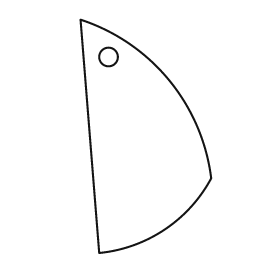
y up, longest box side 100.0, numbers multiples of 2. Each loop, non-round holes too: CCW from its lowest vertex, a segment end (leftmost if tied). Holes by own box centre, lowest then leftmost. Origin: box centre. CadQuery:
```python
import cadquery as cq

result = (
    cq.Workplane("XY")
    .moveTo(-20.0, -50.0)
    .threePointArc((8.0, -40.0), (28.0, -18.0))
    .threePointArc((10.0, 24.0), (-28.0, 50.0))
    .close()
    .moveTo(-16.0, 34.0)
    .circle(4.0)
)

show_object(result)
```